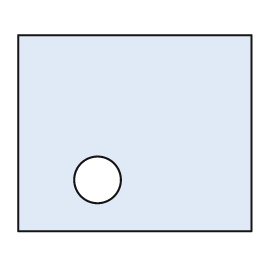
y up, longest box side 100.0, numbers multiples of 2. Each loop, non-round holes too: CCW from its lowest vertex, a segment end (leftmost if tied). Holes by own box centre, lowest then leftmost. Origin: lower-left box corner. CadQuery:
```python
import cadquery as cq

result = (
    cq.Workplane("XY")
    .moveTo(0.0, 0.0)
    .lineTo(100.0, 0.0)
    .lineTo(100.0, 84.0)
    .lineTo(0.0, 84.0)
    .close()
    .moveTo(34.0, 22.0)
    .circle(10.0)
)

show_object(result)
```